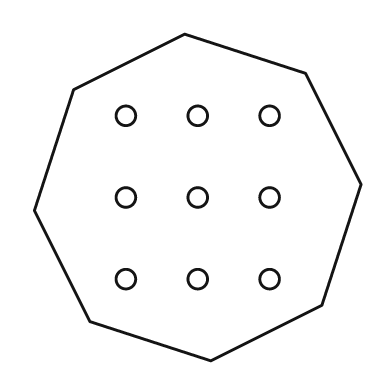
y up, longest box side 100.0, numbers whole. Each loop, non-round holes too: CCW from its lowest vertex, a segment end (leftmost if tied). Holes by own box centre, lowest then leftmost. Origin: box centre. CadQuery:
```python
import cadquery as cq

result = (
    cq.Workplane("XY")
    .moveTo(4.0, -50.0)
    .lineTo(38.0, -33.0)
    .lineTo(50.0, 4.0)
    .lineTo(33.0, 38.0)
    .lineTo(-4.0, 50.0)
    .lineTo(-38.0, 33.0)
    .lineTo(-50.0, -4.0)
    .lineTo(-33.0, -38.0)
    .close()
    .moveTo(-22.0, -25.0)
    .circle(3.0)
    .moveTo(0.0, -25.0)
    .circle(3.0)
    .moveTo(22.0, -25.0)
    .circle(3.0)
    .moveTo(-22.0, 0.0)
    .circle(3.0)
    .moveTo(0.0, 0.0)
    .circle(3.0)
    .moveTo(22.0, 0.0)
    .circle(3.0)
    .moveTo(-22.0, 25.0)
    .circle(3.0)
    .moveTo(0.0, 25.0)
    .circle(3.0)
    .moveTo(22.0, 25.0)
    .circle(3.0)
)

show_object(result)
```